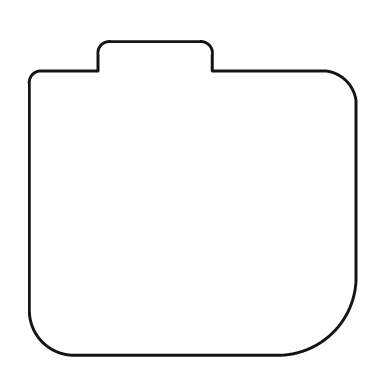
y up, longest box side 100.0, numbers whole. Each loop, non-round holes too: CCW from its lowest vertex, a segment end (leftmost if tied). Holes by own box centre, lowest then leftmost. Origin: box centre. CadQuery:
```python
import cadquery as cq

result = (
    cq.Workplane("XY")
    .moveTo(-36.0, -48.0)
    .lineTo(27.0, -48.0)
    .threePointArc((43.0, -41.0), (50.0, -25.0))
    .lineTo(50.0, 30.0)
    .threePointArc((47.0, 36.0), (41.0, 39.0))
    .lineTo(6.0, 39.0)
    .lineTo(6.0, 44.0)
    .threePointArc((5.0, 47.0), (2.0, 48.0))
    .lineTo(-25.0, 48.0)
    .threePointArc((-28.0, 47.0), (-29.0, 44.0))
    .lineTo(-29.0, 39.0)
    .lineTo(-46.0, 39.0)
    .threePointArc((-49.0, 38.0), (-50.0, 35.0))
    .lineTo(-50.0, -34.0)
    .threePointArc((-46.0, -44.0), (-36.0, -48.0))
    .close()
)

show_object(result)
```